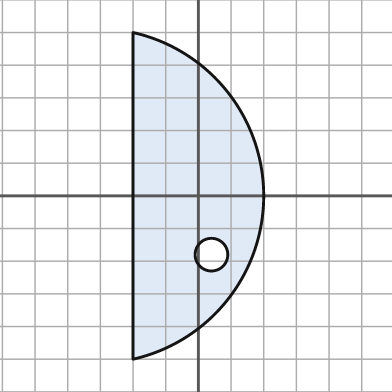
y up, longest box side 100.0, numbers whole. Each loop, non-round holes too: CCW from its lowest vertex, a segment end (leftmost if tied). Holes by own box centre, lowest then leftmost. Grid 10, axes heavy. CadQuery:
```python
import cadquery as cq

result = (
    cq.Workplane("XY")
    .moveTo(-20.0, -50.0)
    .threePointArc((20.0, 0.0), (-20.0, 50.0))
    .close()
    .moveTo(4.0, -18.0)
    .circle(5.0)
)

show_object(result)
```